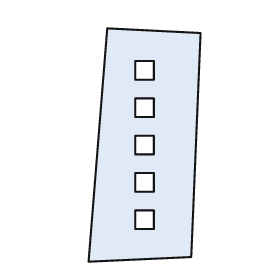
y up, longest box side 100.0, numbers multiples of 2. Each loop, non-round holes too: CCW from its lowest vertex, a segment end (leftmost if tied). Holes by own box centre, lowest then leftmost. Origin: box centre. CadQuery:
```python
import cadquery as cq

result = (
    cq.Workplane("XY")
    .moveTo(-24.0, -50.0)
    .lineTo(20.0, -48.0)
    .lineTo(24.0, 48.0)
    .lineTo(-16.0, 50.0)
    .close()
    .moveTo(-4.0, -36.0)
    .lineTo(4.0, -36.0)
    .lineTo(4.0, -28.0)
    .lineTo(-4.0, -28.0)
    .close()
    .moveTo(-4.0, -20.0)
    .lineTo(4.0, -20.0)
    .lineTo(4.0, -12.0)
    .lineTo(-4.0, -12.0)
    .close()
    .moveTo(-4.0, -4.0)
    .lineTo(4.0, -4.0)
    .lineTo(4.0, 4.0)
    .lineTo(-4.0, 4.0)
    .close()
    .moveTo(-4.0, 12.0)
    .lineTo(4.0, 12.0)
    .lineTo(4.0, 20.0)
    .lineTo(-4.0, 20.0)
    .close()
    .moveTo(-4.0, 28.0)
    .lineTo(4.0, 28.0)
    .lineTo(4.0, 36.0)
    .lineTo(-4.0, 36.0)
    .close()
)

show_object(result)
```